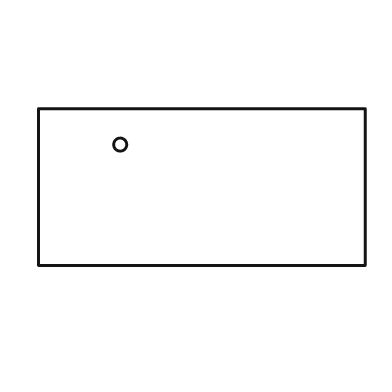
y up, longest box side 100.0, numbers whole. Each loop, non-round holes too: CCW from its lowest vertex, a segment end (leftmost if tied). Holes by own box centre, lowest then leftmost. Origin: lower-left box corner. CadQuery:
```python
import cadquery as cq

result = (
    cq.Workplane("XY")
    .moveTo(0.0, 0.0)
    .lineTo(100.0, 0.0)
    .lineTo(100.0, 48.0)
    .lineTo(0.0, 48.0)
    .close()
    .moveTo(25.0, 37.0)
    .circle(2.0)
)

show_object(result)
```